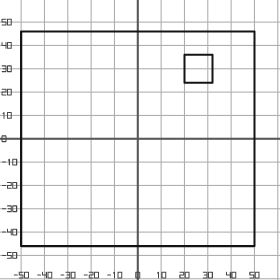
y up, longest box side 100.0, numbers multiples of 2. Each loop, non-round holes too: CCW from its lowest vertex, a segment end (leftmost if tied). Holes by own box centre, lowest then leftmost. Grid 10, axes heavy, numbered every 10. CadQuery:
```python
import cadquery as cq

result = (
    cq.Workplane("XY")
    .moveTo(-50.0, -46.0)
    .lineTo(50.0, -46.0)
    .lineTo(50.0, 46.0)
    .lineTo(-50.0, 46.0)
    .close()
    .moveTo(20.0, 24.0)
    .lineTo(32.0, 24.0)
    .lineTo(32.0, 36.0)
    .lineTo(20.0, 36.0)
    .close()
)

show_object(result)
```